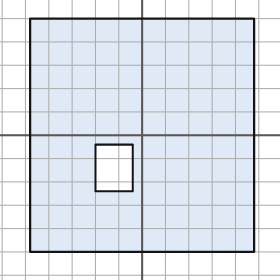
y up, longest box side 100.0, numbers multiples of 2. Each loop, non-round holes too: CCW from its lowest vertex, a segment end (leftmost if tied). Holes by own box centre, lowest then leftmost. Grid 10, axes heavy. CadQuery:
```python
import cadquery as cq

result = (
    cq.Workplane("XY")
    .moveTo(-48.0, -50.0)
    .lineTo(48.0, -50.0)
    .lineTo(48.0, 50.0)
    .lineTo(-48.0, 50.0)
    .close()
    .moveTo(-20.0, -24.0)
    .lineTo(-4.0, -24.0)
    .lineTo(-4.0, -4.0)
    .lineTo(-20.0, -4.0)
    .close()
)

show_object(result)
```